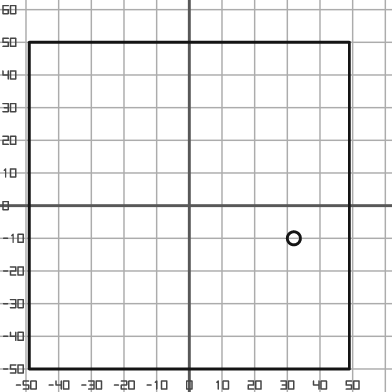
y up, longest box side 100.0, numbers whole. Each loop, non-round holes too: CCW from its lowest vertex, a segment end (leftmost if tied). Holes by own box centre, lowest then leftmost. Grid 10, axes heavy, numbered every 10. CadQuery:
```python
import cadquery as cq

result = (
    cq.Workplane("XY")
    .moveTo(-49.0, -50.0)
    .lineTo(49.0, -50.0)
    .lineTo(49.0, 50.0)
    .lineTo(-49.0, 50.0)
    .close()
    .moveTo(32.0, -10.0)
    .circle(2.0)
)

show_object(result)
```